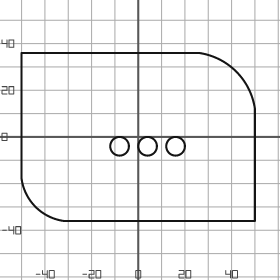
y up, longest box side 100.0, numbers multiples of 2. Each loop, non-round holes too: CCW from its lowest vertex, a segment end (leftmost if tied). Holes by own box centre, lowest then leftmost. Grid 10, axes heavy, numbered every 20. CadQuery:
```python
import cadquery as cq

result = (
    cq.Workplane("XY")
    .moveTo(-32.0, -36.0)
    .lineTo(50.0, -36.0)
    .lineTo(50.0, 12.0)
    .threePointArc((42.0, 28.0), (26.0, 36.0))
    .lineTo(-50.0, 36.0)
    .lineTo(-50.0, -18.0)
    .threePointArc((-44.0, -30.0), (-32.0, -36.0))
    .close()
    .moveTo(-8.0, -4.0)
    .circle(4.0)
    .moveTo(4.0, -4.0)
    .circle(4.0)
    .moveTo(16.0, -4.0)
    .circle(4.0)
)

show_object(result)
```